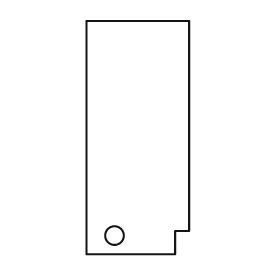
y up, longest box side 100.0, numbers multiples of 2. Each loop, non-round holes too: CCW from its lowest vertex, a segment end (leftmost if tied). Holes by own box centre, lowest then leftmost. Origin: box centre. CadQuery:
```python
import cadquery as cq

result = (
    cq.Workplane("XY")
    .moveTo(-22.0, -50.0)
    .lineTo(16.0, -50.0)
    .lineTo(16.0, -40.0)
    .lineTo(22.0, -40.0)
    .lineTo(22.0, 50.0)
    .lineTo(-22.0, 50.0)
    .close()
    .moveTo(-10.0, -42.0)
    .circle(4.0)
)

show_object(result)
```